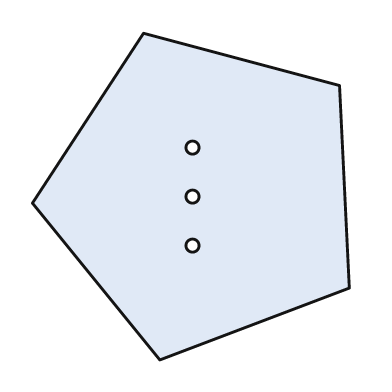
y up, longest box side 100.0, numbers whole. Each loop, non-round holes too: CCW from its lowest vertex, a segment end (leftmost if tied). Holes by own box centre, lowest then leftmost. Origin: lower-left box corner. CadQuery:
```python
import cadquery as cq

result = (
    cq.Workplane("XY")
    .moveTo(39.0, 0.0)
    .lineTo(97.0, 22.0)
    .lineTo(94.0, 84.0)
    .lineTo(34.0, 100.0)
    .lineTo(0.0, 48.0)
    .close()
    .moveTo(49.0, 35.0)
    .circle(2.0)
    .moveTo(49.0, 50.0)
    .circle(2.0)
    .moveTo(49.0, 65.0)
    .circle(2.0)
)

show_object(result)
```